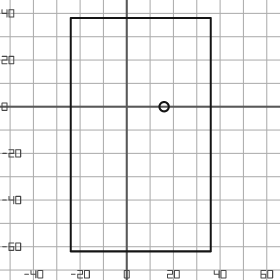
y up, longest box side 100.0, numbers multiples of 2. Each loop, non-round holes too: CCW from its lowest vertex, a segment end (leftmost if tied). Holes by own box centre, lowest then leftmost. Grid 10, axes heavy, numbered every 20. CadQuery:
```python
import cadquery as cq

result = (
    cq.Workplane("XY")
    .moveTo(-24.0, -62.0)
    .lineTo(36.0, -62.0)
    .lineTo(36.0, 38.0)
    .lineTo(-24.0, 38.0)
    .close()
    .moveTo(16.0, 0.0)
    .circle(2.0)
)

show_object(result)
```